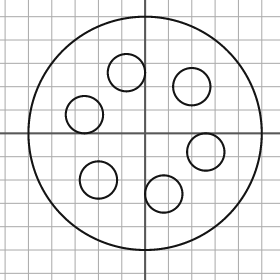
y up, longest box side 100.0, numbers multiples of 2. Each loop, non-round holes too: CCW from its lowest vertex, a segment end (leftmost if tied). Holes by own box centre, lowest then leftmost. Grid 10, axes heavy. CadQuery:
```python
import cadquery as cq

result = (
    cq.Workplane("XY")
    .moveTo(0.0, 0.0)
    .circle(50.0)
    .moveTo(8.0, -26.0)
    .circle(8.0)
    .moveTo(-20.0, -20.0)
    .circle(8.0)
    .moveTo(26.0, -8.0)
    .circle(8.0)
    .moveTo(-26.0, 8.0)
    .circle(8.0)
    .moveTo(20.0, 20.0)
    .circle(8.0)
    .moveTo(-8.0, 26.0)
    .circle(8.0)
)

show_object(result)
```